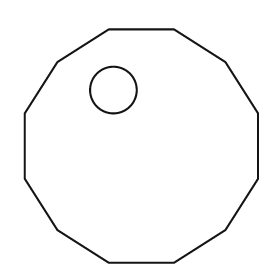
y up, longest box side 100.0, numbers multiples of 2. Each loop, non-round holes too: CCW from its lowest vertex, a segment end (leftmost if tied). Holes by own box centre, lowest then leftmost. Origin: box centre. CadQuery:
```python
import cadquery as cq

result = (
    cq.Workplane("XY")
    .moveTo(-14.0, -50.0)
    .lineTo(14.0, -50.0)
    .lineTo(36.0, -36.0)
    .lineTo(50.0, -14.0)
    .lineTo(50.0, 14.0)
    .lineTo(36.0, 36.0)
    .lineTo(14.0, 50.0)
    .lineTo(-14.0, 50.0)
    .lineTo(-36.0, 36.0)
    .lineTo(-50.0, 14.0)
    .lineTo(-50.0, -14.0)
    .lineTo(-36.0, -36.0)
    .close()
    .moveTo(-12.0, 24.0)
    .circle(10.0)
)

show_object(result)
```